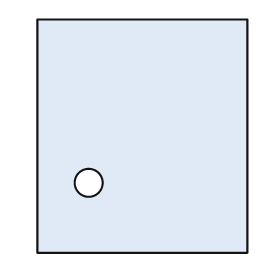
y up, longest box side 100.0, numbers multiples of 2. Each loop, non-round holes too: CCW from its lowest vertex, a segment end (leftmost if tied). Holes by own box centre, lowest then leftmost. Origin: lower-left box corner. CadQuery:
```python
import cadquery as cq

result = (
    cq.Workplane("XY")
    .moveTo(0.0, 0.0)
    .lineTo(90.0, 0.0)
    .lineTo(90.0, 100.0)
    .lineTo(0.0, 100.0)
    .close()
    .moveTo(22.0, 30.0)
    .circle(6.0)
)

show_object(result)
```